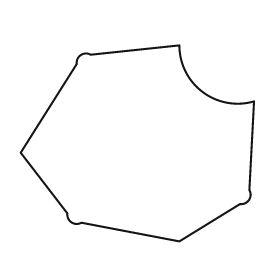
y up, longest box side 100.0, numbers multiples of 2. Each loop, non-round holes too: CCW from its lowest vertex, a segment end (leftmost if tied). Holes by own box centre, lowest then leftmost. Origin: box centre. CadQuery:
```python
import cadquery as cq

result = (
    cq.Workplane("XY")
    .moveTo(18.0, -42.0)
    .lineTo(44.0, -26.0)
    .threePointArc((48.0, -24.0), (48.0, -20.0))
    .lineTo(50.0, 18.0)
    .threePointArc((28.0, 22.0), (18.0, 42.0))
    .lineTo(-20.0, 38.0)
    .threePointArc((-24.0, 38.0), (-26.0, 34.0))
    .lineTo(-50.0, -4.0)
    .lineTo(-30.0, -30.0)
    .threePointArc((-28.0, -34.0), (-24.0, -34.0))
    .close()
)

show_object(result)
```